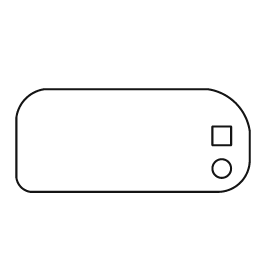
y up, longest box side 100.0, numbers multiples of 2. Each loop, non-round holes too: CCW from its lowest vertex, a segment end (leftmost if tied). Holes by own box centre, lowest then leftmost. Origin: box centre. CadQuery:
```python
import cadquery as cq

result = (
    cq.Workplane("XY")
    .moveTo(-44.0, -22.0)
    .lineTo(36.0, -22.0)
    .threePointArc((46.0, -18.0), (50.0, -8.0))
    .lineTo(50.0, 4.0)
    .threePointArc((44.0, 16.0), (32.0, 22.0))
    .lineTo(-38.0, 22.0)
    .threePointArc((-46.0, 18.0), (-50.0, 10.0))
    .lineTo(-50.0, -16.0)
    .threePointArc((-48.0, -20.0), (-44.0, -22.0))
    .close()
    .moveTo(38.0, -12.0)
    .circle(4.0)
    .moveTo(34.0, -2.0)
    .lineTo(42.0, -2.0)
    .lineTo(42.0, 6.0)
    .lineTo(34.0, 6.0)
    .close()
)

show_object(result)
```